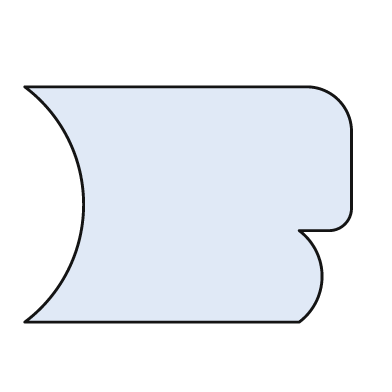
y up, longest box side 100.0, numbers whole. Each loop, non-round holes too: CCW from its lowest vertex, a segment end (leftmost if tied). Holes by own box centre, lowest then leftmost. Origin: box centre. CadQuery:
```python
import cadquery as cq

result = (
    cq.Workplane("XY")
    .moveTo(-50.0, -36.0)
    .lineTo(34.0, -36.0)
    .threePointArc((41.0, -22.0), (34.0, -8.0))
    .lineTo(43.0, -8.0)
    .threePointArc((48.0, -6.0), (50.0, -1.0))
    .lineTo(50.0, 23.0)
    .threePointArc((46.0, 32.0), (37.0, 36.0))
    .lineTo(-50.0, 36.0)
    .threePointArc((-32.0, 0.0), (-50.0, -36.0))
    .close()
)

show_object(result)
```